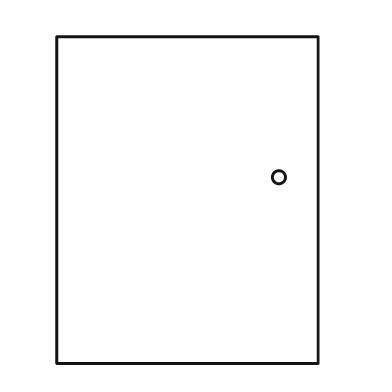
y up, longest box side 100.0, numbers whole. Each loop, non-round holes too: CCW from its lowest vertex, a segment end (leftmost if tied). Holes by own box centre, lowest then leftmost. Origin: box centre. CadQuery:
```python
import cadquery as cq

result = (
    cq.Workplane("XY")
    .moveTo(-40.0, -50.0)
    .lineTo(40.0, -50.0)
    .lineTo(40.0, 50.0)
    .lineTo(-40.0, 50.0)
    .close()
    .moveTo(28.0, 7.0)
    .circle(2.0)
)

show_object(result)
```